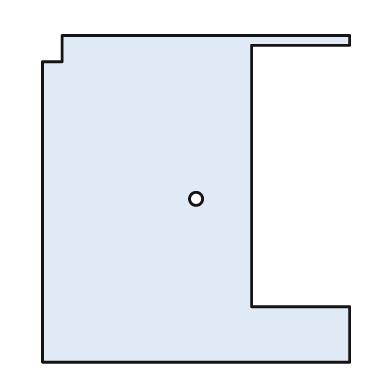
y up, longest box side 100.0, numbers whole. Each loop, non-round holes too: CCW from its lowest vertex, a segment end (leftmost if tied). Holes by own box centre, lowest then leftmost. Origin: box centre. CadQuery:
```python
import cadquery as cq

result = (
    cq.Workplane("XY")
    .moveTo(-47.0, -50.0)
    .lineTo(47.0, -50.0)
    .lineTo(47.0, -33.0)
    .lineTo(17.0, -33.0)
    .lineTo(17.0, 47.0)
    .lineTo(47.0, 47.0)
    .lineTo(47.0, 50.0)
    .lineTo(-41.0, 50.0)
    .lineTo(-41.0, 42.0)
    .lineTo(-47.0, 42.0)
    .close()
    .moveTo(0.0, 0.0)
    .circle(2.0)
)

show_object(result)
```